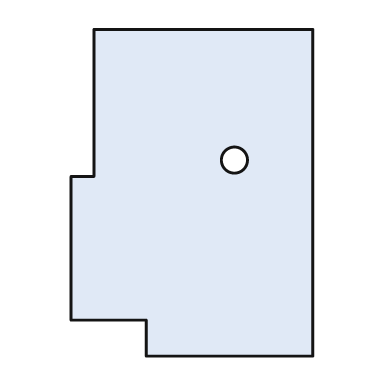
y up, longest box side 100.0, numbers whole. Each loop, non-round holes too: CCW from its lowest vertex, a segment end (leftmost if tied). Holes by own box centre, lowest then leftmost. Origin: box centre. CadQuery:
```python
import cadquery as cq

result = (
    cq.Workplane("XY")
    .moveTo(-14.0, -50.0)
    .lineTo(37.0, -50.0)
    .lineTo(37.0, 50.0)
    .lineTo(-30.0, 50.0)
    .lineTo(-30.0, 5.0)
    .lineTo(-37.0, 5.0)
    .lineTo(-37.0, -39.0)
    .lineTo(-14.0, -39.0)
    .close()
    .moveTo(13.0, 10.0)
    .circle(4.0)
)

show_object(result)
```